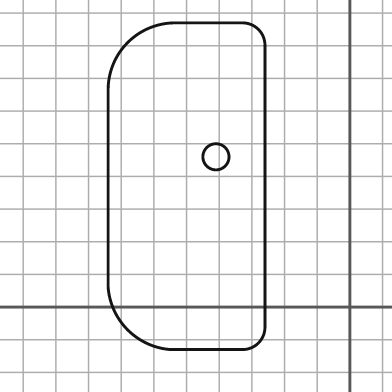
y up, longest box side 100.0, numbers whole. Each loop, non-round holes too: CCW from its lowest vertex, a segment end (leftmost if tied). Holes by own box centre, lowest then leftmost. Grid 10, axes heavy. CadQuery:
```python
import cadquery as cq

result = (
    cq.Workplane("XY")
    .moveTo(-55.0, -13.0)
    .lineTo(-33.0, -13.0)
    .threePointArc((-28.0, -11.0), (-26.0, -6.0))
    .lineTo(-26.0, 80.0)
    .threePointArc((-28.0, 85.0), (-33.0, 87.0))
    .lineTo(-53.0, 87.0)
    .threePointArc((-68.0, 81.0), (-74.0, 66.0))
    .lineTo(-74.0, 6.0)
    .threePointArc((-68.0, -7.0), (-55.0, -13.0))
    .close()
    .moveTo(-41.0, 46.0)
    .circle(4.0)
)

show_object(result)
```